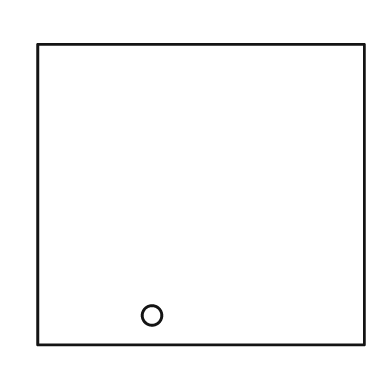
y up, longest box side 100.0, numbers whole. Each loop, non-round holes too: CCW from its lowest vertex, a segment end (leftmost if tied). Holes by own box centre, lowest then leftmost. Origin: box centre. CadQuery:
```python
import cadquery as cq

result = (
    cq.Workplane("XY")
    .moveTo(-50.0, -46.0)
    .lineTo(50.0, -46.0)
    .lineTo(50.0, 46.0)
    .lineTo(-50.0, 46.0)
    .close()
    .moveTo(-15.0, -37.0)
    .circle(3.0)
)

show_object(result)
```